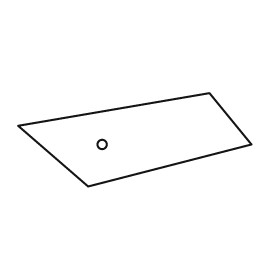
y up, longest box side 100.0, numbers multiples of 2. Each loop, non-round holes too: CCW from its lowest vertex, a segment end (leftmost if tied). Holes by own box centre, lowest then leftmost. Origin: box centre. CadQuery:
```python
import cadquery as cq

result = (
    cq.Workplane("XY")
    .moveTo(-20.0, -20.0)
    .lineTo(50.0, -2.0)
    .lineTo(32.0, 20.0)
    .lineTo(-50.0, 6.0)
    .close()
    .moveTo(-14.0, -2.0)
    .circle(2.0)
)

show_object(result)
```